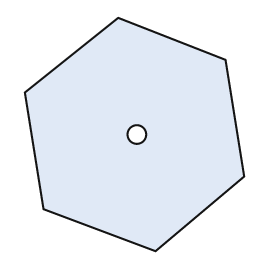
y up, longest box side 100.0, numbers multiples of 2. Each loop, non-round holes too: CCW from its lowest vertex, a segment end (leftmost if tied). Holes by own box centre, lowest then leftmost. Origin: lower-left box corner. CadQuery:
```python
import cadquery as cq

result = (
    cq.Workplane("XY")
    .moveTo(56.0, 0.0)
    .lineTo(94.0, 32.0)
    .lineTo(86.0, 82.0)
    .lineTo(40.0, 100.0)
    .lineTo(0.0, 68.0)
    .lineTo(8.0, 18.0)
    .close()
    .moveTo(48.0, 50.0)
    .circle(4.0)
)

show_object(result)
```